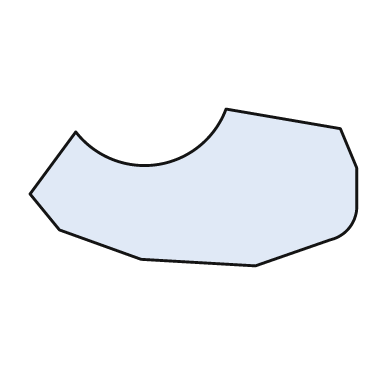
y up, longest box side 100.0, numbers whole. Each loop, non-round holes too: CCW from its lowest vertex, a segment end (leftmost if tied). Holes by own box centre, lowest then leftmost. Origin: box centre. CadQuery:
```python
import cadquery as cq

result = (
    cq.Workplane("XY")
    .moveTo(19.0, -24.0)
    .lineTo(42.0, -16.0)
    .threePointArc((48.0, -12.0), (50.0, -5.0))
    .lineTo(50.0, 6.0)
    .lineTo(45.0, 18.0)
    .lineTo(10.0, 24.0)
    .threePointArc((-11.0, 7.0), (-36.0, 17.0))
    .lineTo(-50.0, -2.0)
    .lineTo(-41.0, -13.0)
    .lineTo(-16.0, -22.0)
    .close()
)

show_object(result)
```